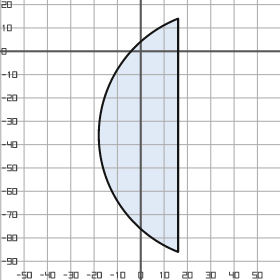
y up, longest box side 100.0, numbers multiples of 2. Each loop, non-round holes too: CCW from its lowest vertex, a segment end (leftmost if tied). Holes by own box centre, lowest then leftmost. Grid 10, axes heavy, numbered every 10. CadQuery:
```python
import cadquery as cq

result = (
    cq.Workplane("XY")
    .moveTo(16.0, -86.0)
    .lineTo(16.0, 14.0)
    .threePointArc((-18.0, -36.0), (16.0, -86.0))
    .close()
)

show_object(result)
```